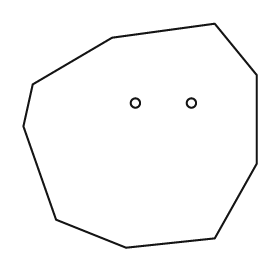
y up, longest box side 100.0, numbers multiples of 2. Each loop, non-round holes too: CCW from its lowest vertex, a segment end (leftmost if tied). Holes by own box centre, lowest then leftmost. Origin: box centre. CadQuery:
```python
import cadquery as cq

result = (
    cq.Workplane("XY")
    .moveTo(-6.0, -48.0)
    .lineTo(32.0, -44.0)
    .lineTo(50.0, -12.0)
    .lineTo(50.0, 26.0)
    .lineTo(32.0, 48.0)
    .lineTo(-12.0, 42.0)
    .lineTo(-46.0, 22.0)
    .lineTo(-50.0, 4.0)
    .lineTo(-36.0, -36.0)
    .close()
    .moveTo(-2.0, 14.0)
    .circle(2.0)
    .moveTo(22.0, 14.0)
    .circle(2.0)
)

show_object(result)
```